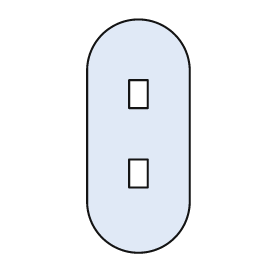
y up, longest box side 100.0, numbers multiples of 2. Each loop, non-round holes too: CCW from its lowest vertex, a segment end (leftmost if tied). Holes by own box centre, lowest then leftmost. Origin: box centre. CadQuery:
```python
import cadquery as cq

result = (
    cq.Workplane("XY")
    .moveTo(-22.0, -28.0)
    .threePointArc((0.0, -50.0), (22.0, -28.0))
    .lineTo(22.0, 28.0)
    .threePointArc((0.0, 50.0), (-22.0, 28.0))
    .close()
    .moveTo(-4.0, -22.0)
    .lineTo(4.0, -22.0)
    .lineTo(4.0, -10.0)
    .lineTo(-4.0, -10.0)
    .close()
    .moveTo(-4.0, 12.0)
    .lineTo(4.0, 12.0)
    .lineTo(4.0, 24.0)
    .lineTo(-4.0, 24.0)
    .close()
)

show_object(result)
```